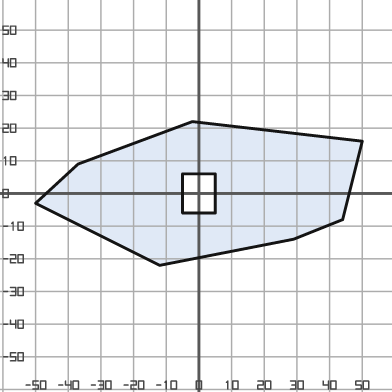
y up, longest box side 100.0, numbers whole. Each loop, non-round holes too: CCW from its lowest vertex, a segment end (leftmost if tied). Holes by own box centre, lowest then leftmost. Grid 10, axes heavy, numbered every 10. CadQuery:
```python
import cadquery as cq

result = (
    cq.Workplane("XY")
    .moveTo(-12.0, -22.0)
    .lineTo(29.0, -14.0)
    .lineTo(44.0, -8.0)
    .lineTo(50.0, 16.0)
    .lineTo(-2.0, 22.0)
    .lineTo(-37.0, 9.0)
    .lineTo(-50.0, -3.0)
    .close()
    .moveTo(-5.0, -6.0)
    .lineTo(5.0, -6.0)
    .lineTo(5.0, 6.0)
    .lineTo(-5.0, 6.0)
    .close()
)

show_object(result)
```